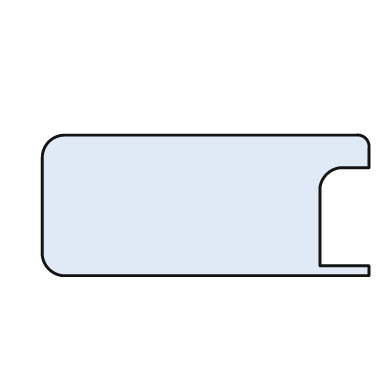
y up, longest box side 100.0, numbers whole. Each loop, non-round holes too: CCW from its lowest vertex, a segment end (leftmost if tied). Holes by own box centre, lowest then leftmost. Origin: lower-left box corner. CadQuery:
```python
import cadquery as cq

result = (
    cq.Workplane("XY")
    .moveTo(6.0, 0.0)
    .lineTo(100.0, 0.0)
    .lineTo(100.0, 3.0)
    .lineTo(85.0, 3.0)
    .lineTo(85.0, 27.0)
    .threePointArc((87.0, 31.0), (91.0, 33.0))
    .lineTo(100.0, 33.0)
    .lineTo(100.0, 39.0)
    .threePointArc((99.0, 42.0), (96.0, 43.0))
    .lineTo(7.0, 43.0)
    .threePointArc((2.0, 41.0), (0.0, 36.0))
    .lineTo(0.0, 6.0)
    .threePointArc((2.0, 2.0), (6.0, 0.0))
    .close()
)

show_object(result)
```